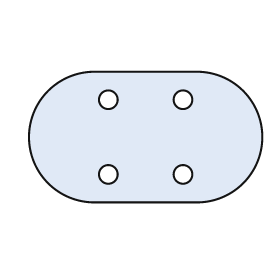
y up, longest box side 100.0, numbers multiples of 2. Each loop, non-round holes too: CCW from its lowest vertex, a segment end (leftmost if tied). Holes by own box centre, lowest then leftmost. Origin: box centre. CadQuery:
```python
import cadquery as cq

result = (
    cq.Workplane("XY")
    .moveTo(-22.0, -28.0)
    .lineTo(22.0, -28.0)
    .threePointArc((50.0, 0.0), (22.0, 28.0))
    .lineTo(-22.0, 28.0)
    .threePointArc((-50.0, 0.0), (-22.0, -28.0))
    .close()
    .moveTo(-16.0, -16.0)
    .circle(4.0)
    .moveTo(16.0, -16.0)
    .circle(4.0)
    .moveTo(-16.0, 16.0)
    .circle(4.0)
    .moveTo(16.0, 16.0)
    .circle(4.0)
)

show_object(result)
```